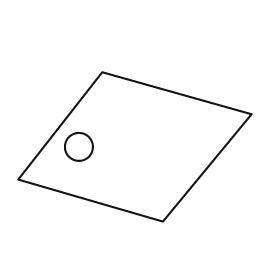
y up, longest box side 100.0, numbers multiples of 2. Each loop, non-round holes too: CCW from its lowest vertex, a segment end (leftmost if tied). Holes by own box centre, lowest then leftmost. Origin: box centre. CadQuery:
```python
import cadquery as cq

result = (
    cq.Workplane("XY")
    .moveTo(12.0, -32.0)
    .lineTo(50.0, 14.0)
    .lineTo(-14.0, 32.0)
    .lineTo(-50.0, -14.0)
    .close()
    .moveTo(-24.0, 0.0)
    .circle(6.0)
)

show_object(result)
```